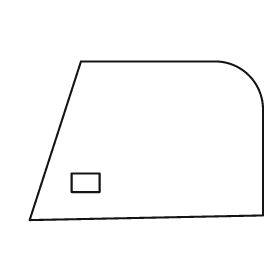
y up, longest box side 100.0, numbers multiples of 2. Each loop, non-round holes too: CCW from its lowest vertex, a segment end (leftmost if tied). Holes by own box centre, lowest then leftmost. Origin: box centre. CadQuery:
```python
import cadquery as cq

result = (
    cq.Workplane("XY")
    .moveTo(-50.0, -34.0)
    .lineTo(50.0, -32.0)
    .lineTo(50.0, 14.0)
    .threePointArc((44.0, 28.0), (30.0, 34.0))
    .lineTo(-28.0, 34.0)
    .close()
    .moveTo(-32.0, -22.0)
    .lineTo(-20.0, -22.0)
    .lineTo(-20.0, -14.0)
    .lineTo(-32.0, -14.0)
    .close()
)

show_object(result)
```